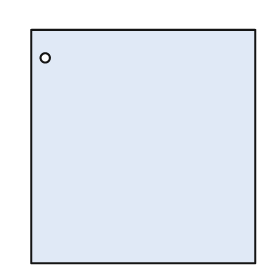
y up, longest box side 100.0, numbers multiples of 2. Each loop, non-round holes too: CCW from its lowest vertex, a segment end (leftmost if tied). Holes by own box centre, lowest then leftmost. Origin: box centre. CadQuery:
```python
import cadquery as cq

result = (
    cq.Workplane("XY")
    .moveTo(-48.0, -50.0)
    .lineTo(48.0, -50.0)
    .lineTo(48.0, 50.0)
    .lineTo(-48.0, 50.0)
    .close()
    .moveTo(-42.0, 38.0)
    .circle(2.0)
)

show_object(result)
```